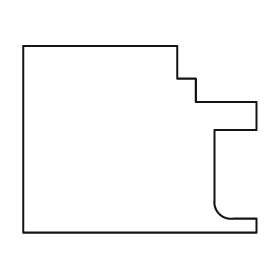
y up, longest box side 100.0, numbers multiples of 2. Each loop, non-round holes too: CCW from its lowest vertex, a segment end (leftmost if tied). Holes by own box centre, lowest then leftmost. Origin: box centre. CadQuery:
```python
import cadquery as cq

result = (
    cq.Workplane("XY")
    .moveTo(-50.0, -40.0)
    .lineTo(50.0, -40.0)
    .lineTo(50.0, -34.0)
    .lineTo(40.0, -34.0)
    .threePointArc((34.0, -32.0), (32.0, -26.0))
    .lineTo(32.0, 4.0)
    .lineTo(50.0, 4.0)
    .lineTo(50.0, 16.0)
    .lineTo(24.0, 16.0)
    .lineTo(24.0, 26.0)
    .lineTo(16.0, 26.0)
    .lineTo(16.0, 40.0)
    .lineTo(-50.0, 40.0)
    .close()
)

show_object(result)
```